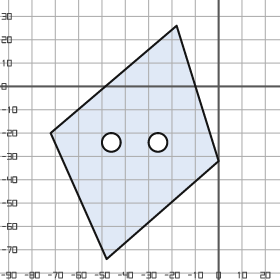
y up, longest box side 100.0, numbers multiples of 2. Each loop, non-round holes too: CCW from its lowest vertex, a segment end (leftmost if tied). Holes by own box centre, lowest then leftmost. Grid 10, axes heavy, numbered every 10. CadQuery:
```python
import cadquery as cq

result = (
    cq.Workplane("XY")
    .moveTo(-48.0, -74.0)
    .lineTo(0.0, -32.0)
    .lineTo(-18.0, 26.0)
    .lineTo(-72.0, -20.0)
    .close()
    .moveTo(-46.0, -24.0)
    .circle(4.0)
    .moveTo(-26.0, -24.0)
    .circle(4.0)
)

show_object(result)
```